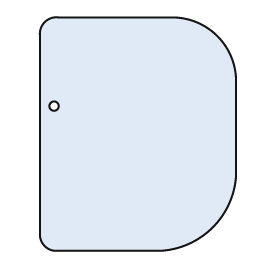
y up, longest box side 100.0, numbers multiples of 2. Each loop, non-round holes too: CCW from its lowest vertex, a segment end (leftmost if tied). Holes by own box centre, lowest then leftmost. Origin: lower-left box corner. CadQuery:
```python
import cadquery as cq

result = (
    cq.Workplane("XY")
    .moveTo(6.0, 0.0)
    .lineTo(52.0, 0.0)
    .threePointArc((74.0, 10.0), (84.0, 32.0))
    .lineTo(84.0, 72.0)
    .threePointArc((76.0, 92.0), (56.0, 100.0))
    .lineTo(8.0, 100.0)
    .threePointArc((2.0, 98.0), (0.0, 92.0))
    .lineTo(0.0, 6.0)
    .threePointArc((2.0, 2.0), (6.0, 0.0))
    .close()
    .moveTo(6.0, 62.0)
    .circle(2.0)
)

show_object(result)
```